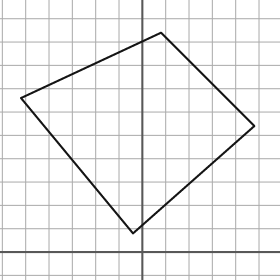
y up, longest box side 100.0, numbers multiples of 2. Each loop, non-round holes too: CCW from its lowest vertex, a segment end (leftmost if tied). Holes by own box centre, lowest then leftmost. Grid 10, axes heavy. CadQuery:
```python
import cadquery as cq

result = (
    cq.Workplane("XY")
    .moveTo(-4.0, 8.0)
    .lineTo(48.0, 54.0)
    .lineTo(8.0, 94.0)
    .lineTo(-52.0, 66.0)
    .close()
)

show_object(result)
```